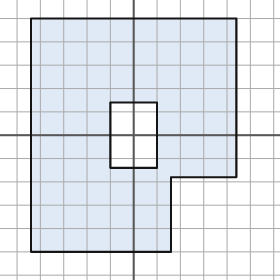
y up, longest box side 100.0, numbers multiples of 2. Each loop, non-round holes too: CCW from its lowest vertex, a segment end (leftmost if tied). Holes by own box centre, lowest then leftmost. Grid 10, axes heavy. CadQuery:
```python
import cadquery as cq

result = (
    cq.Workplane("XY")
    .moveTo(-44.0, -50.0)
    .lineTo(16.0, -50.0)
    .lineTo(16.0, -18.0)
    .lineTo(44.0, -18.0)
    .lineTo(44.0, 50.0)
    .lineTo(-44.0, 50.0)
    .close()
    .moveTo(-10.0, -14.0)
    .lineTo(10.0, -14.0)
    .lineTo(10.0, 14.0)
    .lineTo(-10.0, 14.0)
    .close()
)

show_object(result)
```